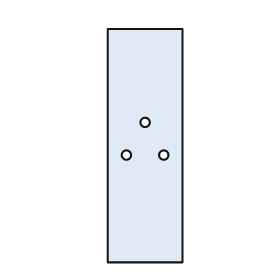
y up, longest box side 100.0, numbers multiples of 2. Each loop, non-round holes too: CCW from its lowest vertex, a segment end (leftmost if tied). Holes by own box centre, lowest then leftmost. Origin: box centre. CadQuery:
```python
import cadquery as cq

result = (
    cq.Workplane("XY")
    .moveTo(-16.0, -50.0)
    .lineTo(16.0, -50.0)
    .lineTo(16.0, 50.0)
    .lineTo(-16.0, 50.0)
    .close()
    .moveTo(-8.0, -4.0)
    .circle(2.0)
    .moveTo(8.0, -4.0)
    .circle(2.0)
    .moveTo(0.0, 10.0)
    .circle(2.0)
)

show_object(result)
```